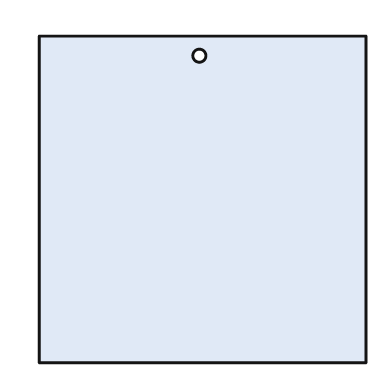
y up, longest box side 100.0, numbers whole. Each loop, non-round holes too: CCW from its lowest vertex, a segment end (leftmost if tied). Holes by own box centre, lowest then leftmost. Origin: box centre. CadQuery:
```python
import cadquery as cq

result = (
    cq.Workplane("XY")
    .moveTo(-50.0, -50.0)
    .lineTo(50.0, -50.0)
    .lineTo(50.0, 50.0)
    .lineTo(-50.0, 50.0)
    .close()
    .moveTo(-1.0, 44.0)
    .circle(2.0)
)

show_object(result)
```